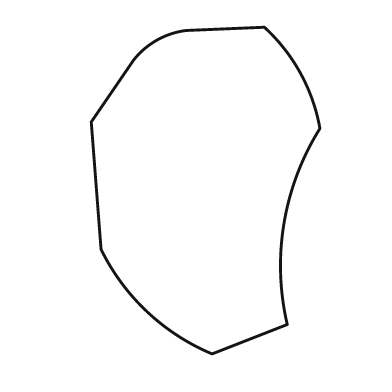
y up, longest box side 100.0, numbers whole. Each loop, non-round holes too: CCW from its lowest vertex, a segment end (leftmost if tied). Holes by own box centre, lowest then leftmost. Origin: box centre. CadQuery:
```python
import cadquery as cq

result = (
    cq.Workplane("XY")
    .moveTo(2.0, -50.0)
    .lineTo(25.0, -41.0)
    .threePointArc((24.0, -10.0), (35.0, 19.0))
    .threePointArc((29.0, 36.0), (18.0, 50.0))
    .lineTo(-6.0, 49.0)
    .threePointArc((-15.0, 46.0), (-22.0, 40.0))
    .lineTo(-35.0, 21.0)
    .lineTo(-32.0, -18.0)
    .threePointArc((-18.0, -37.0), (2.0, -50.0))
    .close()
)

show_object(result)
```